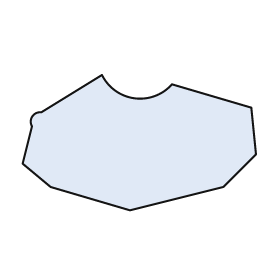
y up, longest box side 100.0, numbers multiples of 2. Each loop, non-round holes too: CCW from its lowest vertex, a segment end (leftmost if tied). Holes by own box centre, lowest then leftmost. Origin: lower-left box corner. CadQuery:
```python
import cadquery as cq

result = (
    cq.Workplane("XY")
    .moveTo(46.0, 0.0)
    .lineTo(86.0, 10.0)
    .lineTo(100.0, 24.0)
    .lineTo(98.0, 44.0)
    .lineTo(64.0, 54.0)
    .threePointArc((48.0, 48.0), (34.0, 58.0))
    .lineTo(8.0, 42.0)
    .threePointArc((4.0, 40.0), (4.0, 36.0))
    .lineTo(0.0, 20.0)
    .lineTo(12.0, 10.0)
    .close()
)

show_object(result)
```